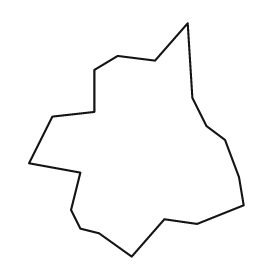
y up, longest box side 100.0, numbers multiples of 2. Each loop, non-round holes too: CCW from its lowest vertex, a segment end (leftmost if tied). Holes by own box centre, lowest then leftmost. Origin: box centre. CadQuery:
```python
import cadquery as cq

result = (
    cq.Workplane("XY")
    .moveTo(-2.0, -50.0)
    .lineTo(12.0, -34.0)
    .lineTo(26.0, -36.0)
    .lineTo(46.0, -28.0)
    .lineTo(44.0, -16.0)
    .lineTo(38.0, 0.0)
    .lineTo(30.0, 6.0)
    .lineTo(24.0, 18.0)
    .lineTo(22.0, 50.0)
    .lineTo(8.0, 34.0)
    .lineTo(-8.0, 36.0)
    .lineTo(-18.0, 30.0)
    .lineTo(-18.0, 12.0)
    .lineTo(-36.0, 10.0)
    .lineTo(-46.0, -10.0)
    .lineTo(-24.0, -14.0)
    .lineTo(-28.0, -30.0)
    .lineTo(-24.0, -38.0)
    .lineTo(-16.0, -40.0)
    .close()
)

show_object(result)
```